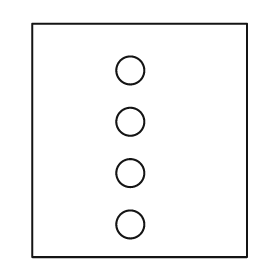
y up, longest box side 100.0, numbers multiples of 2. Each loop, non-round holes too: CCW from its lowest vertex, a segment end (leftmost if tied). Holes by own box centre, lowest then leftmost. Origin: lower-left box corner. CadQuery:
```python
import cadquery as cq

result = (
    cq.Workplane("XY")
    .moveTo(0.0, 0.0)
    .lineTo(92.0, 0.0)
    .lineTo(92.0, 100.0)
    .lineTo(0.0, 100.0)
    .close()
    .moveTo(42.0, 14.0)
    .circle(6.0)
    .moveTo(42.0, 36.0)
    .circle(6.0)
    .moveTo(42.0, 58.0)
    .circle(6.0)
    .moveTo(42.0, 80.0)
    .circle(6.0)
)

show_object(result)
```